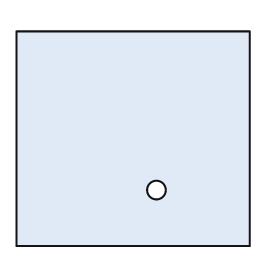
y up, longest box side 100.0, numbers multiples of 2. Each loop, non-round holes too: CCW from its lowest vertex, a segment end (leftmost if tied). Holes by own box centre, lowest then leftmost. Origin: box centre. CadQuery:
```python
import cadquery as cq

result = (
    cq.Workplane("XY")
    .moveTo(-50.0, -46.0)
    .lineTo(50.0, -46.0)
    .lineTo(50.0, 46.0)
    .lineTo(-50.0, 46.0)
    .close()
    .moveTo(10.0, -22.0)
    .circle(4.0)
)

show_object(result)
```